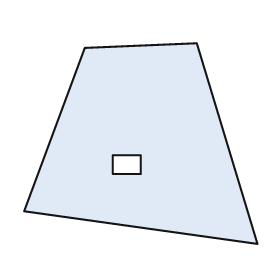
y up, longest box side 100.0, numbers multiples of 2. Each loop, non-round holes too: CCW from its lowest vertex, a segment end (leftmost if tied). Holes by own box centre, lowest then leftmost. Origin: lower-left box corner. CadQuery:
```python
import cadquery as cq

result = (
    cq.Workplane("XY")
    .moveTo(100.0, 0.0)
    .lineTo(74.0, 86.0)
    .lineTo(26.0, 84.0)
    .lineTo(0.0, 14.0)
    .close()
    .moveTo(38.0, 30.0)
    .lineTo(50.0, 30.0)
    .lineTo(50.0, 38.0)
    .lineTo(38.0, 38.0)
    .close()
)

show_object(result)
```